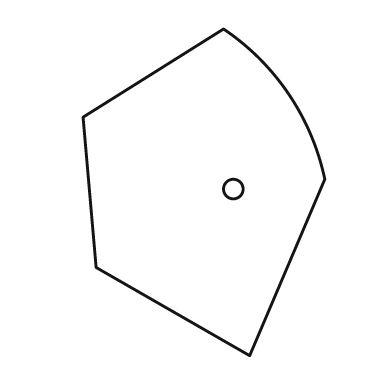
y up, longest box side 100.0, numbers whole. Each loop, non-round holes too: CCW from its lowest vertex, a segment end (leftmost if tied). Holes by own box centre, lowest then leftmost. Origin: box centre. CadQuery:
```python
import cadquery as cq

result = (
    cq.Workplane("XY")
    .moveTo(14.0, -50.0)
    .lineTo(37.0, 4.0)
    .threePointArc((26.0, 30.0), (6.0, 50.0))
    .lineTo(-37.0, 23.0)
    .lineTo(-33.0, -23.0)
    .close()
    .moveTo(9.0, 1.0)
    .circle(3.0)
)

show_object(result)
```